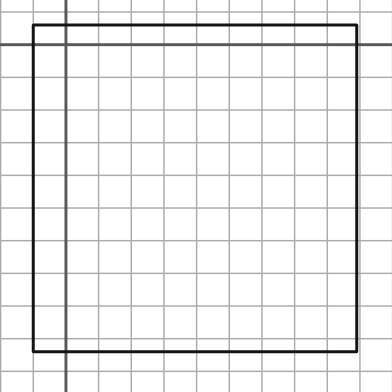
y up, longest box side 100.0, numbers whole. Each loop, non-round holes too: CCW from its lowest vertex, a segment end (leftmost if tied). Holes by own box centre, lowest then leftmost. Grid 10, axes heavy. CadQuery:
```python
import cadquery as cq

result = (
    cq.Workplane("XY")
    .moveTo(-10.0, -94.0)
    .lineTo(89.0, -94.0)
    .lineTo(89.0, 6.0)
    .lineTo(-10.0, 6.0)
    .close()
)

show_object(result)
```